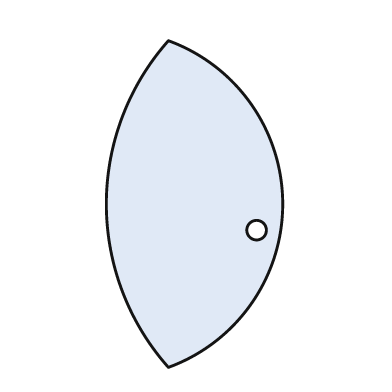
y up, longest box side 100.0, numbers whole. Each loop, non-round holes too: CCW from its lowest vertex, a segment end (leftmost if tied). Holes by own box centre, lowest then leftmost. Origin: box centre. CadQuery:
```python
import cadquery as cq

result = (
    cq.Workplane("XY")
    .moveTo(-8.0, -50.0)
    .threePointArc((27.0, 0.0), (-8.0, 50.0))
    .threePointArc((-27.0, 0.0), (-8.0, -50.0))
    .close()
    .moveTo(19.0, -8.0)
    .circle(3.0)
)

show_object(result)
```